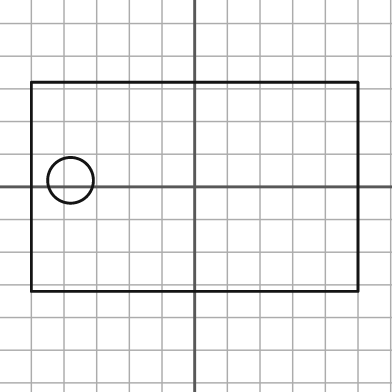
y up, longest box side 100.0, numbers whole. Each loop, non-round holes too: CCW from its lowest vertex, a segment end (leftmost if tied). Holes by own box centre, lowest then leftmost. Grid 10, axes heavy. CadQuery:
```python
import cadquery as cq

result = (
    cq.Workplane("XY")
    .moveTo(-50.0, -32.0)
    .lineTo(50.0, -32.0)
    .lineTo(50.0, 32.0)
    .lineTo(-50.0, 32.0)
    .close()
    .moveTo(-38.0, 2.0)
    .circle(7.0)
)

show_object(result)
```